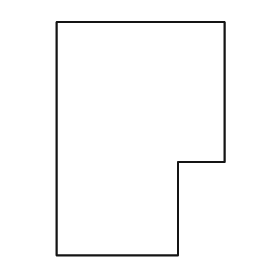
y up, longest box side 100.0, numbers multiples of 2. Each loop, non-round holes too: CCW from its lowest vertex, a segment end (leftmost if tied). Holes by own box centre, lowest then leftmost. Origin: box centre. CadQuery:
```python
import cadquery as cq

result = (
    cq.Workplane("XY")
    .moveTo(-36.0, -50.0)
    .lineTo(16.0, -50.0)
    .lineTo(16.0, -10.0)
    .lineTo(36.0, -10.0)
    .lineTo(36.0, 50.0)
    .lineTo(-36.0, 50.0)
    .close()
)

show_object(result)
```